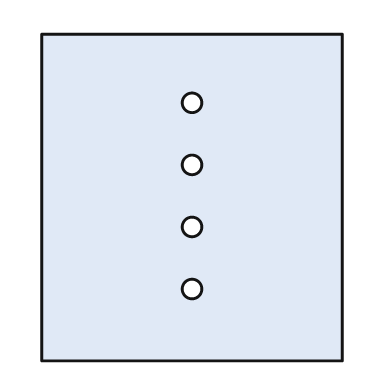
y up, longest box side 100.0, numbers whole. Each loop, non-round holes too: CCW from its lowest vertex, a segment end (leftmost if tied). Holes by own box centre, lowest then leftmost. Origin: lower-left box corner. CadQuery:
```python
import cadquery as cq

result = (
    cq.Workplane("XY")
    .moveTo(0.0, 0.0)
    .lineTo(92.0, 0.0)
    .lineTo(92.0, 100.0)
    .lineTo(0.0, 100.0)
    .close()
    .moveTo(46.0, 22.0)
    .circle(3.0)
    .moveTo(46.0, 41.0)
    .circle(3.0)
    .moveTo(46.0, 60.0)
    .circle(3.0)
    .moveTo(46.0, 79.0)
    .circle(3.0)
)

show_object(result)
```